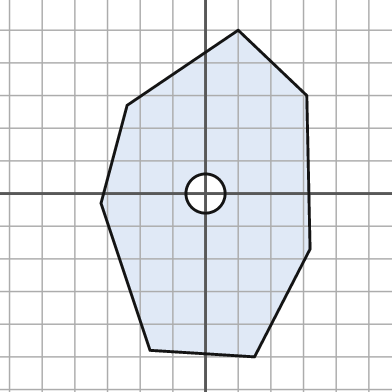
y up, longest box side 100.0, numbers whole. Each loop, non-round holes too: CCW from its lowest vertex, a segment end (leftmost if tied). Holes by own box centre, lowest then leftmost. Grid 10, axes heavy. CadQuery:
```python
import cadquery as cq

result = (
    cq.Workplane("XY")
    .moveTo(15.0, -50.0)
    .lineTo(32.0, -17.0)
    .lineTo(31.0, 30.0)
    .lineTo(10.0, 50.0)
    .lineTo(-24.0, 27.0)
    .lineTo(-32.0, -3.0)
    .lineTo(-17.0, -48.0)
    .close()
    .moveTo(0.0, 0.0)
    .circle(6.0)
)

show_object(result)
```